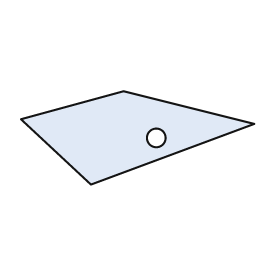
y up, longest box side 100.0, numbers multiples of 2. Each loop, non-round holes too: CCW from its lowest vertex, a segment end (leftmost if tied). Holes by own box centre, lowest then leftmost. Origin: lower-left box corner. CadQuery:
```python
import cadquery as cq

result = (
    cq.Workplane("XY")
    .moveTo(30.0, 0.0)
    .lineTo(100.0, 26.0)
    .lineTo(44.0, 40.0)
    .lineTo(0.0, 28.0)
    .close()
    .moveTo(58.0, 20.0)
    .circle(4.0)
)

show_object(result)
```